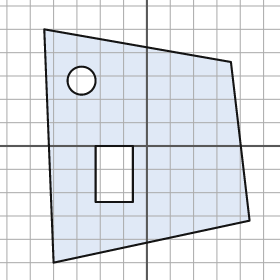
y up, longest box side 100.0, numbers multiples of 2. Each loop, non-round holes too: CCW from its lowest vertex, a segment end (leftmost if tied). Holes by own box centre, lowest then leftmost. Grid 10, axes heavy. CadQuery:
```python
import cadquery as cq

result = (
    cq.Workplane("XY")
    .moveTo(-40.0, -50.0)
    .lineTo(44.0, -32.0)
    .lineTo(36.0, 36.0)
    .lineTo(-44.0, 50.0)
    .close()
    .moveTo(-22.0, -24.0)
    .lineTo(-6.0, -24.0)
    .lineTo(-6.0, 0.0)
    .lineTo(-22.0, 0.0)
    .close()
    .moveTo(-28.0, 28.0)
    .circle(6.0)
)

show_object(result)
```